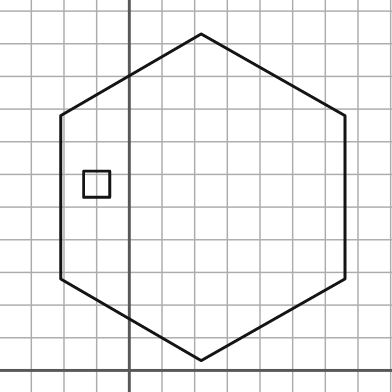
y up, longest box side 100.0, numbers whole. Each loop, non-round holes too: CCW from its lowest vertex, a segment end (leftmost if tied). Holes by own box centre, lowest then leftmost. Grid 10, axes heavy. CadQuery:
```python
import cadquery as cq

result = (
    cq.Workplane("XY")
    .moveTo(22.0, 3.0)
    .lineTo(66.0, 28.0)
    .lineTo(66.0, 78.0)
    .lineTo(22.0, 103.0)
    .lineTo(-21.0, 78.0)
    .lineTo(-21.0, 28.0)
    .close()
    .moveTo(-14.0, 53.0)
    .lineTo(-6.0, 53.0)
    .lineTo(-6.0, 61.0)
    .lineTo(-14.0, 61.0)
    .close()
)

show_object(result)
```